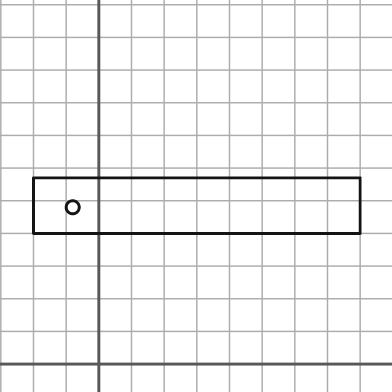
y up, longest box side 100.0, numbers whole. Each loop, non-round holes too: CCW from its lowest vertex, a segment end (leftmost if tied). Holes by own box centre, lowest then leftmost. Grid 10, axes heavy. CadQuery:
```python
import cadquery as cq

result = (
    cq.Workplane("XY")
    .moveTo(-20.0, 40.0)
    .lineTo(80.0, 40.0)
    .lineTo(80.0, 57.0)
    .lineTo(-20.0, 57.0)
    .close()
    .moveTo(-8.0, 48.0)
    .circle(2.0)
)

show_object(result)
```